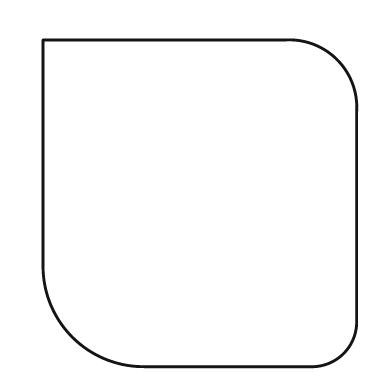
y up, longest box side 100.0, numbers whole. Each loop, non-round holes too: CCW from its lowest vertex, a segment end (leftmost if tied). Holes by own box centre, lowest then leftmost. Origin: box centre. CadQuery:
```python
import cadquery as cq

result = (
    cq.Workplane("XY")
    .moveTo(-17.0, -50.0)
    .lineTo(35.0, -50.0)
    .threePointArc((44.0, -46.0), (48.0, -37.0))
    .lineTo(48.0, 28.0)
    .threePointArc((42.0, 44.0), (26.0, 50.0))
    .lineTo(-48.0, 50.0)
    .lineTo(-48.0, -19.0)
    .threePointArc((-39.0, -41.0), (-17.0, -50.0))
    .close()
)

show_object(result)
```